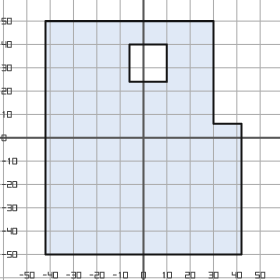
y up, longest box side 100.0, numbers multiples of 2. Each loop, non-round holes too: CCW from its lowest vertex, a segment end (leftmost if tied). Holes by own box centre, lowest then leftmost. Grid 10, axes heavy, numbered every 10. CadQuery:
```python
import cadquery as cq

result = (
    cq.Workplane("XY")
    .moveTo(-42.0, -50.0)
    .lineTo(42.0, -50.0)
    .lineTo(42.0, 6.0)
    .lineTo(30.0, 6.0)
    .lineTo(30.0, 50.0)
    .lineTo(-42.0, 50.0)
    .close()
    .moveTo(-6.0, 24.0)
    .lineTo(10.0, 24.0)
    .lineTo(10.0, 40.0)
    .lineTo(-6.0, 40.0)
    .close()
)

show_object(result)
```